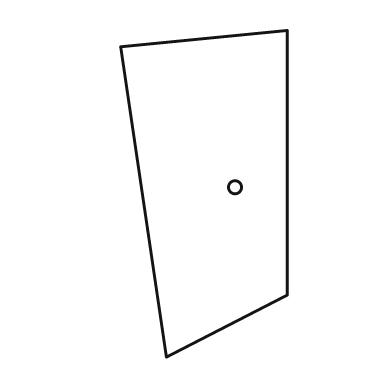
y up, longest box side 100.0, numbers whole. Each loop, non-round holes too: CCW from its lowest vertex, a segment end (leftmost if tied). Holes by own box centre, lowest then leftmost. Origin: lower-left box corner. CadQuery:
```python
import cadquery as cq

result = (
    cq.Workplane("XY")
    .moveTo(14.0, 0.0)
    .lineTo(51.0, 19.0)
    .lineTo(51.0, 100.0)
    .lineTo(0.0, 95.0)
    .close()
    .moveTo(35.0, 52.0)
    .circle(2.0)
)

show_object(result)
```